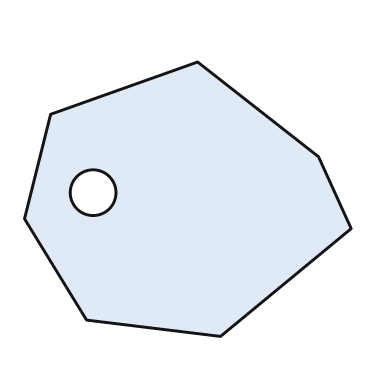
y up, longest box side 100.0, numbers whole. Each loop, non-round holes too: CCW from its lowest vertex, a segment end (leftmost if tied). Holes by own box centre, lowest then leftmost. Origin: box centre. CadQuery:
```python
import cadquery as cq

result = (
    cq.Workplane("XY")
    .moveTo(10.0, -42.0)
    .lineTo(50.0, -9.0)
    .lineTo(40.0, 13.0)
    .lineTo(3.0, 42.0)
    .lineTo(-42.0, 26.0)
    .lineTo(-50.0, -6.0)
    .lineTo(-31.0, -37.0)
    .close()
    .moveTo(-29.0, 2.0)
    .circle(7.0)
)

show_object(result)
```